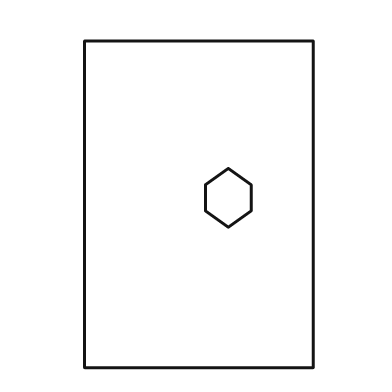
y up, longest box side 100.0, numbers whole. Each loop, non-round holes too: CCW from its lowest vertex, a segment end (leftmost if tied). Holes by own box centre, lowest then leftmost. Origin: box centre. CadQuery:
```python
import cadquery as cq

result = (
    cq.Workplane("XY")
    .moveTo(-35.0, -50.0)
    .lineTo(35.0, -50.0)
    .lineTo(35.0, 50.0)
    .lineTo(-35.0, 50.0)
    .close()
    .moveTo(9.0, -7.0)
    .lineTo(16.0, -2.0)
    .lineTo(16.0, 6.0)
    .lineTo(9.0, 11.0)
    .lineTo(2.0, 6.0)
    .lineTo(2.0, -2.0)
    .close()
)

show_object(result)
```